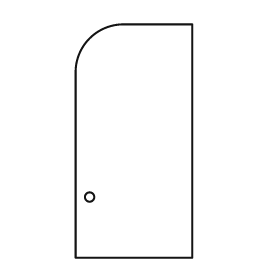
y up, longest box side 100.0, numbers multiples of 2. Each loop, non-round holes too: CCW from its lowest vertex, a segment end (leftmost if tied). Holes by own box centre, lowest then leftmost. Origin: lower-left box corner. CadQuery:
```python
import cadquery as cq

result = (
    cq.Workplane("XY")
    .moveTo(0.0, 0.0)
    .lineTo(50.0, 0.0)
    .lineTo(50.0, 100.0)
    .lineTo(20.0, 100.0)
    .threePointArc((6.0, 94.0), (0.0, 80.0))
    .close()
    .moveTo(6.0, 26.0)
    .circle(2.0)
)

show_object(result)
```